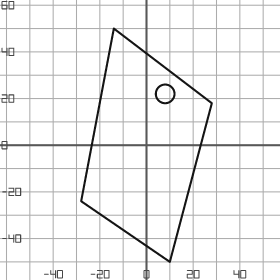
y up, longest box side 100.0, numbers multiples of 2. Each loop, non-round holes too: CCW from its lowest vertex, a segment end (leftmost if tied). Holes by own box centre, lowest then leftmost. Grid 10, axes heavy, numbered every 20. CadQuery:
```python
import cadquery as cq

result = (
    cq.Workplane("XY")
    .moveTo(10.0, -50.0)
    .lineTo(28.0, 18.0)
    .lineTo(-14.0, 50.0)
    .lineTo(-28.0, -24.0)
    .close()
    .moveTo(8.0, 22.0)
    .circle(4.0)
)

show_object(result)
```